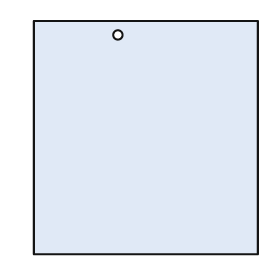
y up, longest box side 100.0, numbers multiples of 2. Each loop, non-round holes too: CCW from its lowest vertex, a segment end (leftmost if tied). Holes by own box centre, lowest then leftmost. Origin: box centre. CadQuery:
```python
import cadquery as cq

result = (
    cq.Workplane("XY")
    .moveTo(-48.0, -50.0)
    .lineTo(48.0, -50.0)
    .lineTo(48.0, 50.0)
    .lineTo(-48.0, 50.0)
    .close()
    .moveTo(-12.0, 44.0)
    .circle(2.0)
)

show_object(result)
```